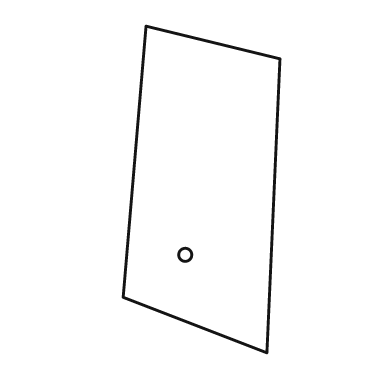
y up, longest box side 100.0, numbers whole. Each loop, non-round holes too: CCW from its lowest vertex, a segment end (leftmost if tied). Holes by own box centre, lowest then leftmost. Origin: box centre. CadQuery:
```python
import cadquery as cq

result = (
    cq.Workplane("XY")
    .moveTo(20.0, -50.0)
    .lineTo(24.0, 40.0)
    .lineTo(-17.0, 50.0)
    .lineTo(-24.0, -33.0)
    .close()
    .moveTo(-5.0, -20.0)
    .circle(2.0)
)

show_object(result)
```